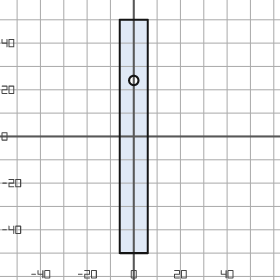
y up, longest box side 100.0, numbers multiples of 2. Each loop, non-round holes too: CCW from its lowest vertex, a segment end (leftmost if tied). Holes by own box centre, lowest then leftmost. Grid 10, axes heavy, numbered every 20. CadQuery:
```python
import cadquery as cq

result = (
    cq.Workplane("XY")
    .moveTo(-6.0, -50.0)
    .lineTo(6.0, -50.0)
    .lineTo(6.0, 50.0)
    .lineTo(-6.0, 50.0)
    .close()
    .moveTo(0.0, 24.0)
    .circle(2.0)
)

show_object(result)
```